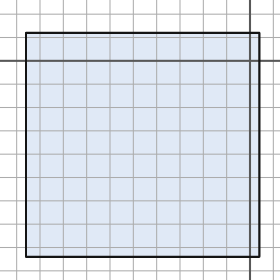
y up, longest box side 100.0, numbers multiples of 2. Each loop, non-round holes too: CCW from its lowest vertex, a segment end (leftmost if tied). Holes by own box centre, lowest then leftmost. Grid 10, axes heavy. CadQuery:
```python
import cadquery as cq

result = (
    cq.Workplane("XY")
    .moveTo(-96.0, -84.0)
    .lineTo(4.0, -84.0)
    .lineTo(4.0, 12.0)
    .lineTo(-96.0, 12.0)
    .close()
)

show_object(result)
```